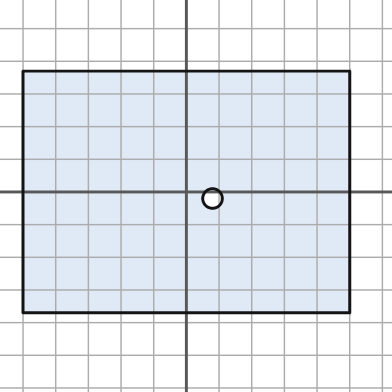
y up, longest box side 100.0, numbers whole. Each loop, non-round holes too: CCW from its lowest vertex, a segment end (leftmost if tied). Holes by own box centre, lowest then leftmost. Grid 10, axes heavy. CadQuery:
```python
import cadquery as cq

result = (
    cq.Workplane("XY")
    .moveTo(-50.0, -37.0)
    .lineTo(50.0, -37.0)
    .lineTo(50.0, 37.0)
    .lineTo(-50.0, 37.0)
    .close()
    .moveTo(8.0, -2.0)
    .circle(3.0)
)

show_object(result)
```